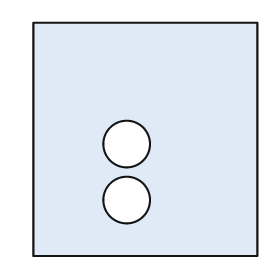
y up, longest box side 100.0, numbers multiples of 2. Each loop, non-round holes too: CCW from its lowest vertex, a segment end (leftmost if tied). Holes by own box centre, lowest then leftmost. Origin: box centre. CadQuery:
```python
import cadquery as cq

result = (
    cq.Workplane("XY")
    .moveTo(-48.0, -50.0)
    .lineTo(48.0, -50.0)
    .lineTo(48.0, 50.0)
    .lineTo(-48.0, 50.0)
    .close()
    .moveTo(-8.0, -26.0)
    .circle(10.0)
    .moveTo(-8.0, -2.0)
    .circle(10.0)
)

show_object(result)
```